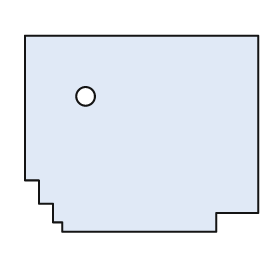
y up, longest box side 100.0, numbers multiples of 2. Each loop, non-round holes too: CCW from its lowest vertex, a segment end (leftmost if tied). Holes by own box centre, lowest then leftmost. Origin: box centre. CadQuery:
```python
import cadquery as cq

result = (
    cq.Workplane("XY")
    .moveTo(-34.0, -42.0)
    .lineTo(32.0, -42.0)
    .lineTo(32.0, -34.0)
    .lineTo(50.0, -34.0)
    .lineTo(50.0, 42.0)
    .lineTo(-50.0, 42.0)
    .lineTo(-50.0, -20.0)
    .lineTo(-44.0, -20.0)
    .lineTo(-44.0, -30.0)
    .lineTo(-38.0, -30.0)
    .lineTo(-38.0, -38.0)
    .lineTo(-34.0, -38.0)
    .close()
    .moveTo(-24.0, 16.0)
    .circle(4.0)
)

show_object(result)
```